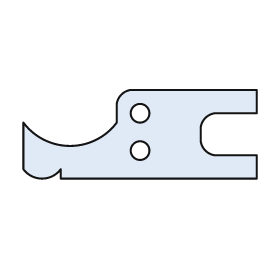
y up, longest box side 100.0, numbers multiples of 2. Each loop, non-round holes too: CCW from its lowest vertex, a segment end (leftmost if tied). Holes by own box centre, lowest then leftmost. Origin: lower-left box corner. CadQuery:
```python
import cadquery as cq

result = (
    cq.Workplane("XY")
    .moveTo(16.0, 0.0)
    .lineTo(100.0, 0.0)
    .lineTo(100.0, 10.0)
    .lineTo(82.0, 10.0)
    .threePointArc((78.0, 12.0), (76.0, 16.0))
    .lineTo(76.0, 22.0)
    .threePointArc((78.0, 26.0), (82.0, 28.0))
    .lineTo(100.0, 28.0)
    .lineTo(100.0, 38.0)
    .lineTo(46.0, 38.0)
    .threePointArc((42.0, 36.0), (40.0, 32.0))
    .lineTo(40.0, 24.0)
    .threePointArc((20.0, 14.0), (0.0, 24.0))
    .lineTo(0.0, 4.0)
    .threePointArc((8.0, 0.0), (16.0, 4.0))
    .close()
    .moveTo(50.0, 12.0)
    .circle(4.0)
    .moveTo(50.0, 28.0)
    .circle(4.0)
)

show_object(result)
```